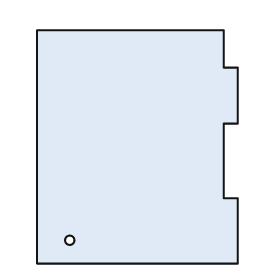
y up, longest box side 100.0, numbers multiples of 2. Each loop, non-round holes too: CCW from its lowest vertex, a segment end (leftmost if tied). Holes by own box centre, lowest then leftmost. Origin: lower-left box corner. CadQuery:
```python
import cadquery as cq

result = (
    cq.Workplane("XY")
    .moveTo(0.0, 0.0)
    .lineTo(86.0, 0.0)
    .lineTo(86.0, 28.0)
    .lineTo(80.0, 28.0)
    .lineTo(80.0, 60.0)
    .lineTo(86.0, 60.0)
    .lineTo(86.0, 84.0)
    .lineTo(80.0, 84.0)
    .lineTo(80.0, 100.0)
    .lineTo(0.0, 100.0)
    .close()
    .moveTo(14.0, 10.0)
    .circle(2.0)
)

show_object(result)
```